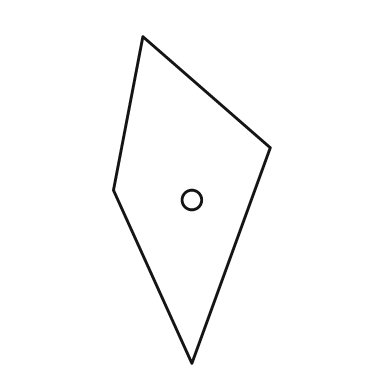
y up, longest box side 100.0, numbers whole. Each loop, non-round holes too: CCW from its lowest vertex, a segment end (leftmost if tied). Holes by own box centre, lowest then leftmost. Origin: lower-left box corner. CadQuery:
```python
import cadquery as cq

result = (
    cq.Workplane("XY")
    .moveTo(24.0, 0.0)
    .lineTo(48.0, 66.0)
    .lineTo(9.0, 100.0)
    .lineTo(0.0, 53.0)
    .close()
    .moveTo(24.0, 50.0)
    .circle(3.0)
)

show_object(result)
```